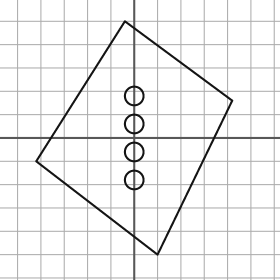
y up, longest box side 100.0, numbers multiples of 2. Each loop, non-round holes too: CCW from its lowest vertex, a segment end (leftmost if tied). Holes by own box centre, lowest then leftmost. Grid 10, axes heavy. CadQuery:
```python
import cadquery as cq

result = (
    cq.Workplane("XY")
    .moveTo(10.0, -50.0)
    .lineTo(42.0, 16.0)
    .lineTo(-4.0, 50.0)
    .lineTo(-42.0, -10.0)
    .close()
    .moveTo(0.0, -18.0)
    .circle(4.0)
    .moveTo(0.0, -6.0)
    .circle(4.0)
    .moveTo(0.0, 6.0)
    .circle(4.0)
    .moveTo(0.0, 18.0)
    .circle(4.0)
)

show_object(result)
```